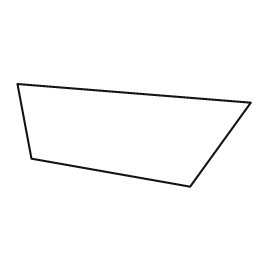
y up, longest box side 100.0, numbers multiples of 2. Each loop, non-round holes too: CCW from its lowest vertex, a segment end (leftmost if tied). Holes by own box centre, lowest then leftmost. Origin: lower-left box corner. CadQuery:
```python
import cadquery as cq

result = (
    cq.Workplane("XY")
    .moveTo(74.0, 0.0)
    .lineTo(100.0, 36.0)
    .lineTo(0.0, 44.0)
    .lineTo(6.0, 12.0)
    .close()
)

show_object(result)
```